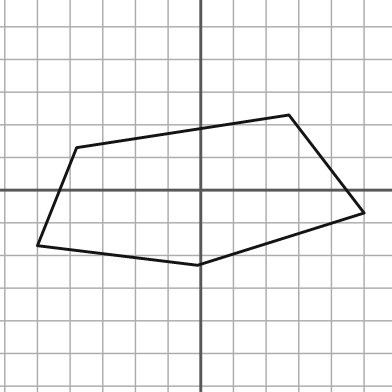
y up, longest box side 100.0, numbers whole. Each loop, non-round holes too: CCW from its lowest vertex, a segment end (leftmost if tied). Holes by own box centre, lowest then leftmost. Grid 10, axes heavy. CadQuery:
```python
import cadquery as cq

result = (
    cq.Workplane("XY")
    .moveTo(-1.0, -23.0)
    .lineTo(50.0, -7.0)
    .lineTo(27.0, 23.0)
    .lineTo(-38.0, 13.0)
    .lineTo(-50.0, -17.0)
    .close()
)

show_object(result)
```